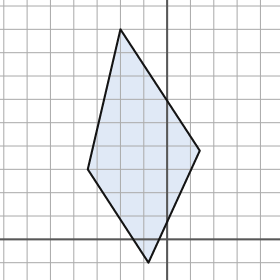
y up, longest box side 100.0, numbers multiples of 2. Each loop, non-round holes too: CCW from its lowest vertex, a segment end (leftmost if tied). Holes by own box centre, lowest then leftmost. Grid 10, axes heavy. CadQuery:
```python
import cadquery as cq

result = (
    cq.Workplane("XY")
    .moveTo(-8.0, -10.0)
    .lineTo(14.0, 38.0)
    .lineTo(-20.0, 90.0)
    .lineTo(-34.0, 30.0)
    .close()
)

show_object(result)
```